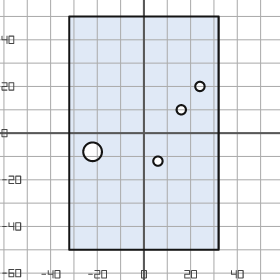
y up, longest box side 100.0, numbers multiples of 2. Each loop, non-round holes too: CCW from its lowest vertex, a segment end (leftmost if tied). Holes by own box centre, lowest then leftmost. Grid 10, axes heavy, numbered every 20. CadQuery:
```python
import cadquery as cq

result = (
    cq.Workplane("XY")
    .moveTo(-32.0, -50.0)
    .lineTo(32.0, -50.0)
    .lineTo(32.0, 50.0)
    .lineTo(-32.0, 50.0)
    .close()
    .moveTo(6.0, -12.0)
    .circle(2.0)
    .moveTo(-22.0, -8.0)
    .circle(4.0)
    .moveTo(16.0, 10.0)
    .circle(2.0)
    .moveTo(24.0, 20.0)
    .circle(2.0)
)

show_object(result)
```